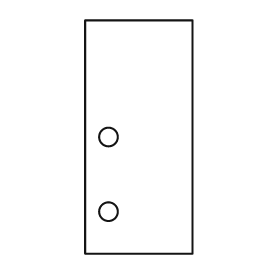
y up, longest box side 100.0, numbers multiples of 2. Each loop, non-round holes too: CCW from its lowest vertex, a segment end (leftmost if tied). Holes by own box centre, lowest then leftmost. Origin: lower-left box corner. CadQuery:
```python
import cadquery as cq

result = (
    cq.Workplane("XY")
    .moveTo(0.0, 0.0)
    .lineTo(46.0, 0.0)
    .lineTo(46.0, 100.0)
    .lineTo(0.0, 100.0)
    .close()
    .moveTo(10.0, 18.0)
    .circle(4.0)
    .moveTo(10.0, 50.0)
    .circle(4.0)
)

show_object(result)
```